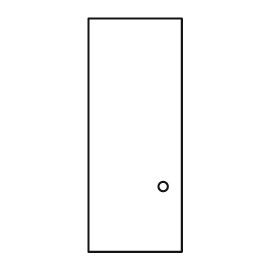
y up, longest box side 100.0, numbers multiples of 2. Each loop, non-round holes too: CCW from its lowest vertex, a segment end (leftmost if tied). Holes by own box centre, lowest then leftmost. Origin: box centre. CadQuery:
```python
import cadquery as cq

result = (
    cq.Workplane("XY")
    .moveTo(-20.0, -50.0)
    .lineTo(20.0, -50.0)
    .lineTo(20.0, 50.0)
    .lineTo(-20.0, 50.0)
    .close()
    .moveTo(12.0, -22.0)
    .circle(2.0)
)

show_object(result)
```